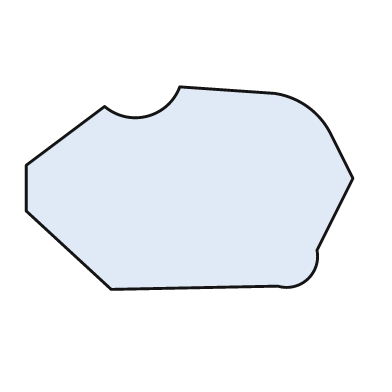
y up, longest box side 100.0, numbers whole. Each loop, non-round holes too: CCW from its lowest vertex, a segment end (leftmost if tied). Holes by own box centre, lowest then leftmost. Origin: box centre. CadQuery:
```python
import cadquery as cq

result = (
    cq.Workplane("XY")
    .moveTo(-24.0, -31.0)
    .lineTo(27.0, -30.0)
    .threePointArc((36.0, -28.0), (39.0, -19.0))
    .lineTo(50.0, 3.0)
    .lineTo(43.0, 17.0)
    .threePointArc((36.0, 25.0), (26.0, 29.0))
    .lineTo(-3.0, 31.0)
    .threePointArc((-13.0, 22.0), (-26.0, 25.0))
    .lineTo(-50.0, 7.0)
    .lineTo(-50.0, -7.0)
    .close()
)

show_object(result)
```